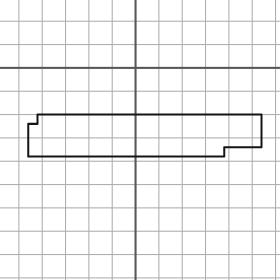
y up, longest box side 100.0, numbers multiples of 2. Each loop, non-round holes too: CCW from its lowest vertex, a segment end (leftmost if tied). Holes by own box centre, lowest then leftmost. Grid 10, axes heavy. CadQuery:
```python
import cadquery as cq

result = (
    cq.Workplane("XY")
    .moveTo(-46.0, -38.0)
    .lineTo(38.0, -38.0)
    .lineTo(38.0, -34.0)
    .lineTo(54.0, -34.0)
    .lineTo(54.0, -20.0)
    .lineTo(-42.0, -20.0)
    .lineTo(-42.0, -24.0)
    .lineTo(-46.0, -24.0)
    .close()
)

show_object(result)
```